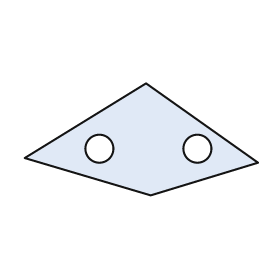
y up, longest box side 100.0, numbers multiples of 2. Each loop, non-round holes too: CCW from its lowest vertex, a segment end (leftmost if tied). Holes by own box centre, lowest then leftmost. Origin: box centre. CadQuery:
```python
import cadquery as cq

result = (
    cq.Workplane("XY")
    .moveTo(4.0, -24.0)
    .lineTo(50.0, -10.0)
    .lineTo(2.0, 24.0)
    .lineTo(-50.0, -8.0)
    .close()
    .moveTo(-18.0, -4.0)
    .circle(6.0)
    .moveTo(24.0, -4.0)
    .circle(6.0)
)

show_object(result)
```